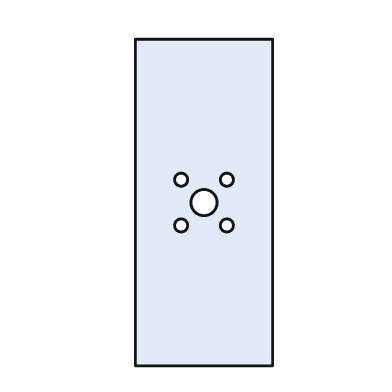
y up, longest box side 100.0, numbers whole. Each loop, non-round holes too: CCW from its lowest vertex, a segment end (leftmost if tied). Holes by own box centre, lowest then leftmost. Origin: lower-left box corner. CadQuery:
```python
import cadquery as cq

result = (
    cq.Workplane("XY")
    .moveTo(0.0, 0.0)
    .lineTo(42.0, 0.0)
    .lineTo(42.0, 100.0)
    .lineTo(0.0, 100.0)
    .close()
    .moveTo(14.0, 43.0)
    .circle(2.0)
    .moveTo(28.0, 43.0)
    .circle(2.0)
    .moveTo(21.0, 50.0)
    .circle(4.0)
    .moveTo(14.0, 57.0)
    .circle(2.0)
    .moveTo(28.0, 57.0)
    .circle(2.0)
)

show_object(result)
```